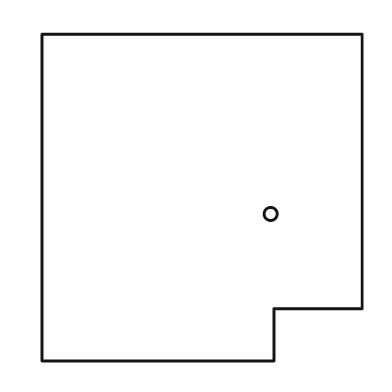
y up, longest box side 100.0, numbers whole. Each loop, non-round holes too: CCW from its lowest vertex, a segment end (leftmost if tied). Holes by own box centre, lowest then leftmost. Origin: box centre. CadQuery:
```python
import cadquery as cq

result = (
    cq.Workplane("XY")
    .moveTo(-49.0, -50.0)
    .lineTo(22.0, -50.0)
    .lineTo(22.0, -34.0)
    .lineTo(49.0, -34.0)
    .lineTo(49.0, 50.0)
    .lineTo(-49.0, 50.0)
    .close()
    .moveTo(21.0, -5.0)
    .circle(2.0)
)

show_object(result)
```